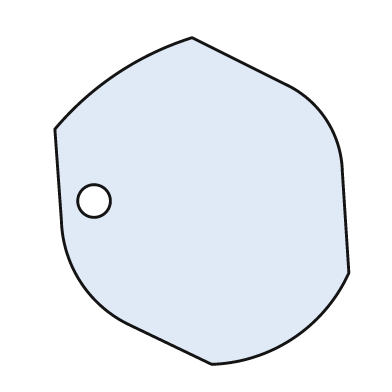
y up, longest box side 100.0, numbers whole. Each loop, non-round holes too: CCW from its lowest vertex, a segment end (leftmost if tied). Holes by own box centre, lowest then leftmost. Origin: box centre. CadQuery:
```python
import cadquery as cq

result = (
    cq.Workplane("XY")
    .moveTo(3.0, -50.0)
    .threePointArc((28.0, -42.0), (45.0, -22.0))
    .lineTo(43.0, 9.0)
    .threePointArc((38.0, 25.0), (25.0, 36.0))
    .lineTo(-3.0, 50.0)
    .threePointArc((-26.0, 39.0), (-45.0, 22.0))
    .lineTo(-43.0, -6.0)
    .threePointArc((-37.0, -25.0), (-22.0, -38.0))
    .close()
    .moveTo(-33.0, 0.0)
    .circle(5.0)
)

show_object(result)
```